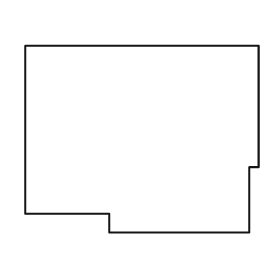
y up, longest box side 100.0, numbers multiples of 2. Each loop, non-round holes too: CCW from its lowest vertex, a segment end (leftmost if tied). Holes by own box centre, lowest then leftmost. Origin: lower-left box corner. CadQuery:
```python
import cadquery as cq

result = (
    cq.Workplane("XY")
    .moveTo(36.0, 0.0)
    .lineTo(96.0, 0.0)
    .lineTo(96.0, 28.0)
    .lineTo(100.0, 28.0)
    .lineTo(100.0, 80.0)
    .lineTo(0.0, 80.0)
    .lineTo(0.0, 8.0)
    .lineTo(36.0, 8.0)
    .close()
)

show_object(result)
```